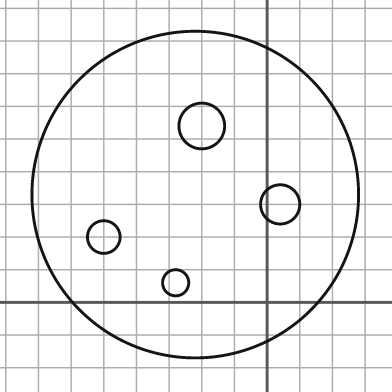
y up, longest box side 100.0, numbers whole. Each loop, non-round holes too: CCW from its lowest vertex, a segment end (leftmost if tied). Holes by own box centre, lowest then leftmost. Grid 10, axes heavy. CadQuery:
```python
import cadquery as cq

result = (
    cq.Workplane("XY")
    .moveTo(-22.0, 33.0)
    .circle(50.0)
    .moveTo(-28.0, 6.0)
    .circle(4.0)
    .moveTo(-50.0, 20.0)
    .circle(5.0)
    .moveTo(4.0, 30.0)
    .circle(6.0)
    .moveTo(-20.0, 54.0)
    .circle(7.0)
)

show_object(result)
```